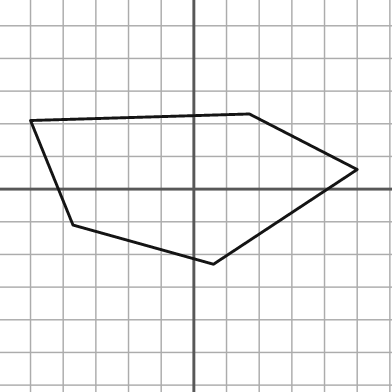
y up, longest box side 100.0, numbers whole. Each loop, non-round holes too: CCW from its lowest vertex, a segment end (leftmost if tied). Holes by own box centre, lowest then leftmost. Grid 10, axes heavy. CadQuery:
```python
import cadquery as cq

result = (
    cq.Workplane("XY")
    .moveTo(6.0, -23.0)
    .lineTo(50.0, 6.0)
    .lineTo(17.0, 23.0)
    .lineTo(-50.0, 21.0)
    .lineTo(-37.0, -11.0)
    .close()
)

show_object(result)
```